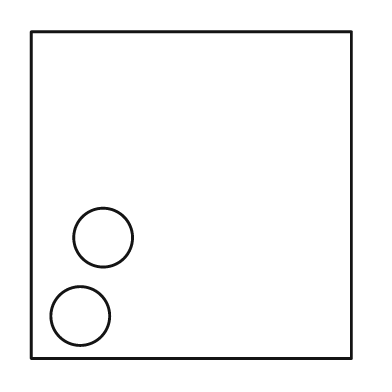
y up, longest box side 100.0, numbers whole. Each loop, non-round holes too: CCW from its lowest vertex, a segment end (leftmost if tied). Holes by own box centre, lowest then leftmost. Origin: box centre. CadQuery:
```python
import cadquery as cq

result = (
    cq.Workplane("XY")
    .moveTo(-49.0, -50.0)
    .lineTo(49.0, -50.0)
    .lineTo(49.0, 50.0)
    .lineTo(-49.0, 50.0)
    .close()
    .moveTo(-34.0, -37.0)
    .circle(9.0)
    .moveTo(-27.0, -13.0)
    .circle(9.0)
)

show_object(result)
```